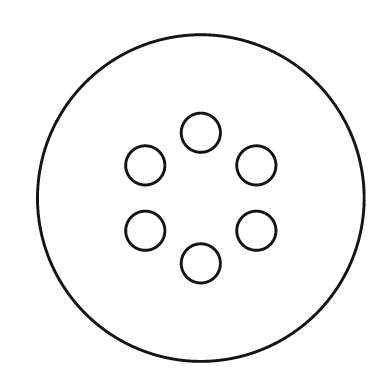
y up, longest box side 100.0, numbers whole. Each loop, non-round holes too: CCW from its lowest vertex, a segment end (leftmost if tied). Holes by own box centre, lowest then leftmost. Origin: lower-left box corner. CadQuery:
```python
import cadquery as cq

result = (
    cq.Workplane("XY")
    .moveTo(50.0, 50.0)
    .circle(50.0)
    .moveTo(50.0, 30.0)
    .circle(6.0)
    .moveTo(33.0, 40.0)
    .circle(6.0)
    .moveTo(67.0, 40.0)
    .circle(6.0)
    .moveTo(33.0, 60.0)
    .circle(6.0)
    .moveTo(67.0, 60.0)
    .circle(6.0)
    .moveTo(50.0, 70.0)
    .circle(6.0)
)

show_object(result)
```